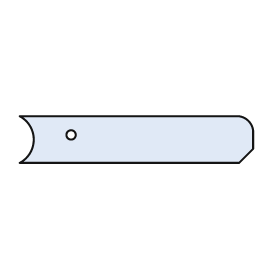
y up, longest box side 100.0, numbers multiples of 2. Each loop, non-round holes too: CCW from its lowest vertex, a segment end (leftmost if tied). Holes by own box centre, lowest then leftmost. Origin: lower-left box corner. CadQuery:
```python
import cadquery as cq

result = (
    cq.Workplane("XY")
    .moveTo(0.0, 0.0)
    .lineTo(94.0, 0.0)
    .lineTo(100.0, 6.0)
    .lineTo(100.0, 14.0)
    .threePointArc((98.0, 18.0), (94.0, 20.0))
    .lineTo(0.0, 20.0)
    .threePointArc((6.0, 10.0), (0.0, 0.0))
    .close()
    .moveTo(22.0, 12.0)
    .circle(2.0)
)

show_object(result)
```